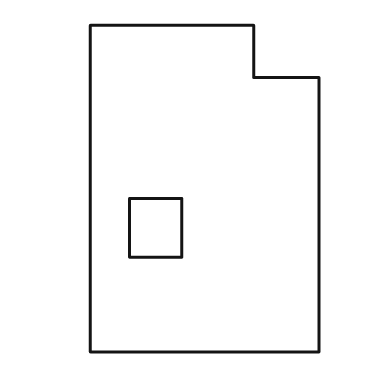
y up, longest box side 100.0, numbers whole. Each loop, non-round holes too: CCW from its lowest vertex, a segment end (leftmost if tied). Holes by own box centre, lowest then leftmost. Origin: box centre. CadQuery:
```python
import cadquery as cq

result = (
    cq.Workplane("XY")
    .moveTo(-35.0, -50.0)
    .lineTo(35.0, -50.0)
    .lineTo(35.0, 34.0)
    .lineTo(15.0, 34.0)
    .lineTo(15.0, 50.0)
    .lineTo(-35.0, 50.0)
    .close()
    .moveTo(-23.0, -21.0)
    .lineTo(-7.0, -21.0)
    .lineTo(-7.0, -3.0)
    .lineTo(-23.0, -3.0)
    .close()
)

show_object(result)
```